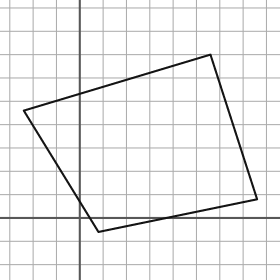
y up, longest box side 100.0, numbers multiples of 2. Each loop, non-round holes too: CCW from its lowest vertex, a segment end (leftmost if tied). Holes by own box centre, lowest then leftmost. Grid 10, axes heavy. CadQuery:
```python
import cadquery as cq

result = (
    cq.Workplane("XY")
    .moveTo(8.0, -6.0)
    .lineTo(76.0, 8.0)
    .lineTo(56.0, 70.0)
    .lineTo(-24.0, 46.0)
    .close()
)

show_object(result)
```